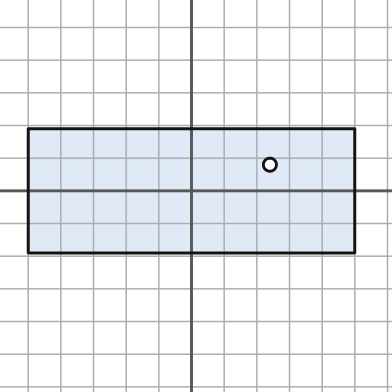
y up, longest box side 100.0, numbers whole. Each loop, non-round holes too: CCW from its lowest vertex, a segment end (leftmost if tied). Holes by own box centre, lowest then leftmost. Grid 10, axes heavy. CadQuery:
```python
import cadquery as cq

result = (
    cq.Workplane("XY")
    .moveTo(-50.0, -19.0)
    .lineTo(50.0, -19.0)
    .lineTo(50.0, 19.0)
    .lineTo(-50.0, 19.0)
    .close()
    .moveTo(24.0, 8.0)
    .circle(2.0)
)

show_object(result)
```